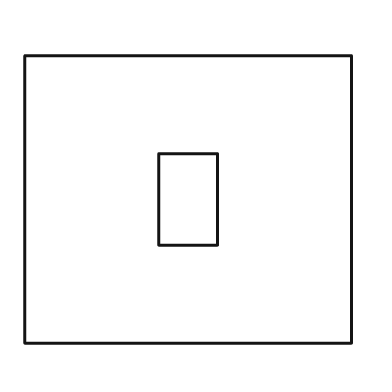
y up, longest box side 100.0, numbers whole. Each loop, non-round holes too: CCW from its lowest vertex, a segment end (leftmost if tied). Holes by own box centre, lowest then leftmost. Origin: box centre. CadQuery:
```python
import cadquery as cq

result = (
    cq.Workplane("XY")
    .moveTo(-50.0, -44.0)
    .lineTo(50.0, -44.0)
    .lineTo(50.0, 44.0)
    .lineTo(-50.0, 44.0)
    .close()
    .moveTo(-9.0, -14.0)
    .lineTo(9.0, -14.0)
    .lineTo(9.0, 14.0)
    .lineTo(-9.0, 14.0)
    .close()
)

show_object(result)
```